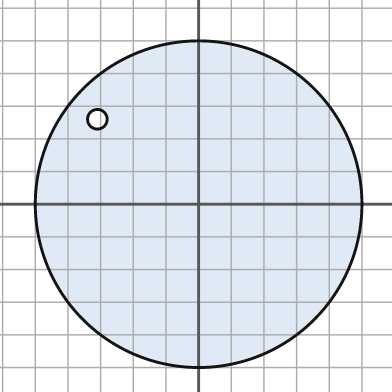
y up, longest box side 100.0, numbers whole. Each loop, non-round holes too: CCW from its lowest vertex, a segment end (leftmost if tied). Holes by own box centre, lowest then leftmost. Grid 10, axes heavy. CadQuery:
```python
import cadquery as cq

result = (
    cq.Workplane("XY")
    .moveTo(0.0, 0.0)
    .circle(50.0)
    .moveTo(-31.0, 26.0)
    .circle(3.0)
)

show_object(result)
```